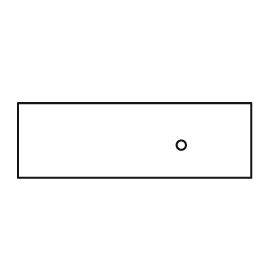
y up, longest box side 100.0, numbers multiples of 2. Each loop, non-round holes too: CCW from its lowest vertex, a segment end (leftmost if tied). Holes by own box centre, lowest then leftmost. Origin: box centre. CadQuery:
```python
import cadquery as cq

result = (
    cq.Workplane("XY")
    .moveTo(-50.0, -16.0)
    .lineTo(50.0, -16.0)
    .lineTo(50.0, 16.0)
    .lineTo(-50.0, 16.0)
    .close()
    .moveTo(20.0, -2.0)
    .circle(2.0)
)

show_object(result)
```